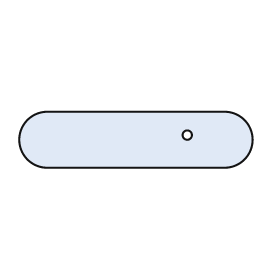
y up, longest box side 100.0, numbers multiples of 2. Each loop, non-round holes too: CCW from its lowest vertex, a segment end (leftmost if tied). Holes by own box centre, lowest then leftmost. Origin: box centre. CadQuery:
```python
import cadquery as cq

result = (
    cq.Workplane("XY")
    .moveTo(-38.0, -12.0)
    .lineTo(38.0, -12.0)
    .threePointArc((50.0, 0.0), (38.0, 12.0))
    .lineTo(-38.0, 12.0)
    .threePointArc((-50.0, 0.0), (-38.0, -12.0))
    .close()
    .moveTo(22.0, 2.0)
    .circle(2.0)
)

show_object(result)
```